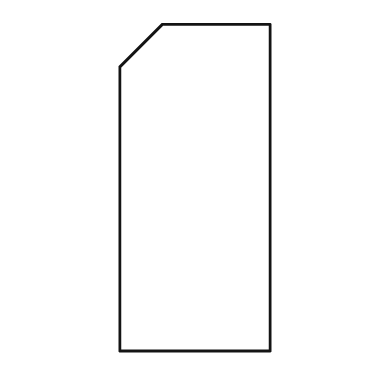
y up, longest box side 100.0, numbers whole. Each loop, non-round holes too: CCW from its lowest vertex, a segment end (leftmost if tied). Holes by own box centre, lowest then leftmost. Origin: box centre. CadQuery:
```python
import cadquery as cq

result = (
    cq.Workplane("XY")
    .moveTo(-23.0, -50.0)
    .lineTo(23.0, -50.0)
    .lineTo(23.0, 50.0)
    .lineTo(-10.0, 50.0)
    .lineTo(-23.0, 37.0)
    .close()
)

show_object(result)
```